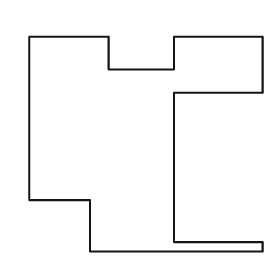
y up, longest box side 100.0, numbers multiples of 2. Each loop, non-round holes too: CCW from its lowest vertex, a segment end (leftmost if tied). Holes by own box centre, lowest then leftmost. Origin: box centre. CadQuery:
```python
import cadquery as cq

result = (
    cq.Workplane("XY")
    .moveTo(-24.0, -46.0)
    .lineTo(50.0, -46.0)
    .lineTo(50.0, -42.0)
    .lineTo(12.0, -42.0)
    .lineTo(12.0, 22.0)
    .lineTo(50.0, 22.0)
    .lineTo(50.0, 46.0)
    .lineTo(12.0, 46.0)
    .lineTo(12.0, 32.0)
    .lineTo(-16.0, 32.0)
    .lineTo(-16.0, 46.0)
    .lineTo(-50.0, 46.0)
    .lineTo(-50.0, -24.0)
    .lineTo(-24.0, -24.0)
    .close()
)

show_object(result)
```